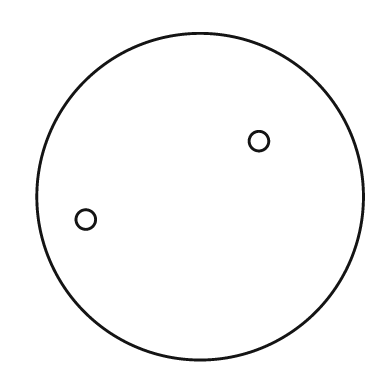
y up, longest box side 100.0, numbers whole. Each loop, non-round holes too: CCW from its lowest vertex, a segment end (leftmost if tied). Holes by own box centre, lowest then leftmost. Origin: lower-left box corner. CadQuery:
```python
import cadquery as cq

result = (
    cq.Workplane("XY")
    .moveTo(50.0, 50.0)
    .circle(50.0)
    .moveTo(15.0, 43.0)
    .circle(3.0)
    .moveTo(68.0, 67.0)
    .circle(3.0)
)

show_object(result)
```